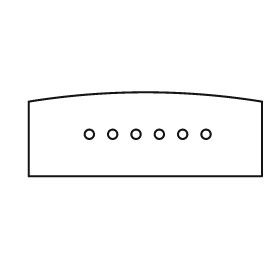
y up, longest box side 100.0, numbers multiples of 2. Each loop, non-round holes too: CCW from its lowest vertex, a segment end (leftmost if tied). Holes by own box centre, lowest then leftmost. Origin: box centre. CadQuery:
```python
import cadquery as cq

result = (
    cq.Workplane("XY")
    .moveTo(-50.0, -18.0)
    .lineTo(50.0, -18.0)
    .lineTo(50.0, 14.0)
    .threePointArc((0.0, 18.0), (-50.0, 14.0))
    .close()
    .moveTo(-24.0, 0.0)
    .circle(2.0)
    .moveTo(-14.0, 0.0)
    .circle(2.0)
    .moveTo(-4.0, 0.0)
    .circle(2.0)
    .moveTo(6.0, 0.0)
    .circle(2.0)
    .moveTo(16.0, 0.0)
    .circle(2.0)
    .moveTo(26.0, 0.0)
    .circle(2.0)
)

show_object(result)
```